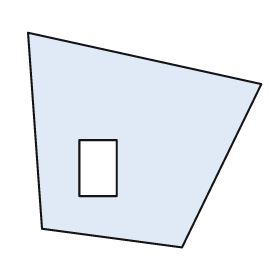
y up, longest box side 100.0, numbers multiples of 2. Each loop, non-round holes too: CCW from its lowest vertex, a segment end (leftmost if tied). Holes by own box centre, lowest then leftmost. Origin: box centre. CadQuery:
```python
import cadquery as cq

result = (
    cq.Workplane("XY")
    .moveTo(16.0, -46.0)
    .lineTo(50.0, 24.0)
    .lineTo(-50.0, 46.0)
    .lineTo(-44.0, -38.0)
    .close()
    .moveTo(-28.0, -24.0)
    .lineTo(-12.0, -24.0)
    .lineTo(-12.0, 0.0)
    .lineTo(-28.0, 0.0)
    .close()
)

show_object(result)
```